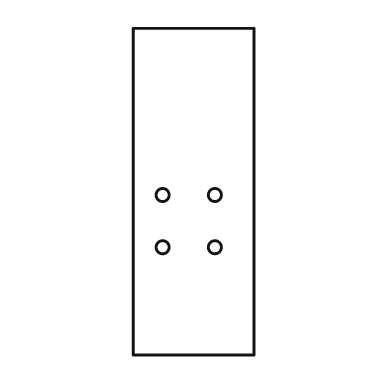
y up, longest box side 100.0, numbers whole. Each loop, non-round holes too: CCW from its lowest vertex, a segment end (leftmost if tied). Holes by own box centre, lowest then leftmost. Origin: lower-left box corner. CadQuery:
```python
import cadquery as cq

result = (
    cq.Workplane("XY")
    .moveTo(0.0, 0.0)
    .lineTo(37.0, 0.0)
    .lineTo(37.0, 100.0)
    .lineTo(0.0, 100.0)
    .close()
    .moveTo(9.0, 33.0)
    .circle(2.0)
    .moveTo(25.0, 33.0)
    .circle(2.0)
    .moveTo(9.0, 49.0)
    .circle(2.0)
    .moveTo(25.0, 49.0)
    .circle(2.0)
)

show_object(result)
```